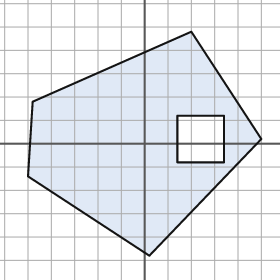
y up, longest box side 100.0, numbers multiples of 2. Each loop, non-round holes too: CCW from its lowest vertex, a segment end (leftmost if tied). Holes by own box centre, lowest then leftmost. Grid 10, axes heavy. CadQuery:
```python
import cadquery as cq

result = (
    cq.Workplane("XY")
    .moveTo(2.0, -48.0)
    .lineTo(50.0, 2.0)
    .lineTo(20.0, 48.0)
    .lineTo(-48.0, 18.0)
    .lineTo(-50.0, -14.0)
    .close()
    .moveTo(14.0, -8.0)
    .lineTo(34.0, -8.0)
    .lineTo(34.0, 12.0)
    .lineTo(14.0, 12.0)
    .close()
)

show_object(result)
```